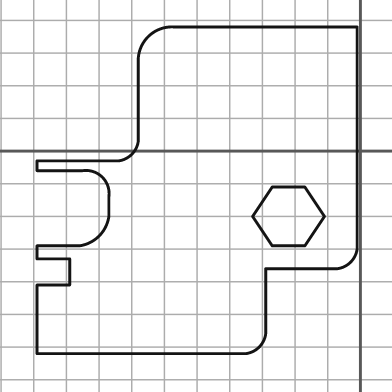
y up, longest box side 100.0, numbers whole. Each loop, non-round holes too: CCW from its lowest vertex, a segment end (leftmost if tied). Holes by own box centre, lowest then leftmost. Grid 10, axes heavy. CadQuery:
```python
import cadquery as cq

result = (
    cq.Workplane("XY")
    .moveTo(-99.0, -62.0)
    .lineTo(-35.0, -62.0)
    .threePointArc((-31.0, -60.0), (-29.0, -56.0))
    .lineTo(-29.0, -36.0)
    .lineTo(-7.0, -36.0)
    .threePointArc((-3.0, -34.0), (-1.0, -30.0))
    .lineTo(-1.0, 38.0)
    .lineTo(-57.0, 38.0)
    .threePointArc((-65.0, 35.0), (-68.0, 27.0))
    .lineTo(-68.0, 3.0)
    .threePointArc((-70.0, -1.0), (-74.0, -3.0))
    .lineTo(-99.0, -3.0)
    .lineTo(-99.0, -6.0)
    .lineTo(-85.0, -6.0)
    .threePointArc((-79.0, -8.0), (-77.0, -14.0))
    .lineTo(-77.0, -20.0)
    .threePointArc((-80.0, -26.0), (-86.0, -29.0))
    .lineTo(-99.0, -29.0)
    .lineTo(-99.0, -33.0)
    .lineTo(-89.0, -33.0)
    .lineTo(-89.0, -41.0)
    .lineTo(-99.0, -41.0)
    .close()
    .moveTo(-27.0, -29.0)
    .lineTo(-17.0, -29.0)
    .lineTo(-11.0, -20.0)
    .lineTo(-17.0, -11.0)
    .lineTo(-27.0, -11.0)
    .lineTo(-33.0, -20.0)
    .close()
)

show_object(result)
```